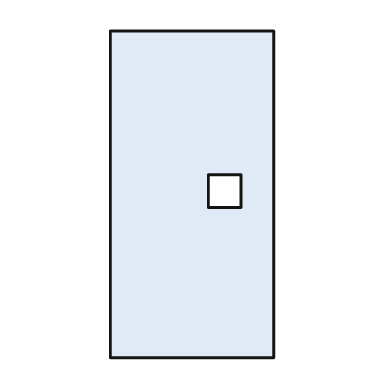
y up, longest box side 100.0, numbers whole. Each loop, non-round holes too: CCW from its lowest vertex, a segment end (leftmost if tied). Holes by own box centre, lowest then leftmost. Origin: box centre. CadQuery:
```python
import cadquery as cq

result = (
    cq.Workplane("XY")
    .moveTo(-25.0, -50.0)
    .lineTo(25.0, -50.0)
    .lineTo(25.0, 50.0)
    .lineTo(-25.0, 50.0)
    .close()
    .moveTo(5.0, -4.0)
    .lineTo(15.0, -4.0)
    .lineTo(15.0, 6.0)
    .lineTo(5.0, 6.0)
    .close()
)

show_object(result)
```